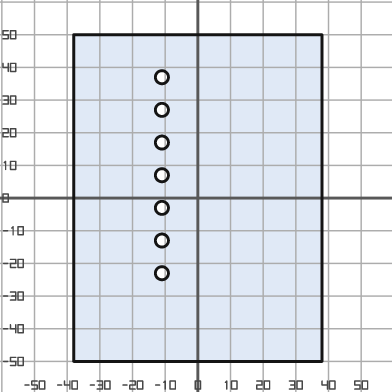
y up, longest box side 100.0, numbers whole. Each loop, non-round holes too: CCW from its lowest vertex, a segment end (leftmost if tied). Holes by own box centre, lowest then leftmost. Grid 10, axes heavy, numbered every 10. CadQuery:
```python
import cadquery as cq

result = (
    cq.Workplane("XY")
    .moveTo(-38.0, -50.0)
    .lineTo(38.0, -50.0)
    .lineTo(38.0, 50.0)
    .lineTo(-38.0, 50.0)
    .close()
    .moveTo(-11.0, -23.0)
    .circle(2.0)
    .moveTo(-11.0, -13.0)
    .circle(2.0)
    .moveTo(-11.0, -3.0)
    .circle(2.0)
    .moveTo(-11.0, 7.0)
    .circle(2.0)
    .moveTo(-11.0, 17.0)
    .circle(2.0)
    .moveTo(-11.0, 27.0)
    .circle(2.0)
    .moveTo(-11.0, 37.0)
    .circle(2.0)
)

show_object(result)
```